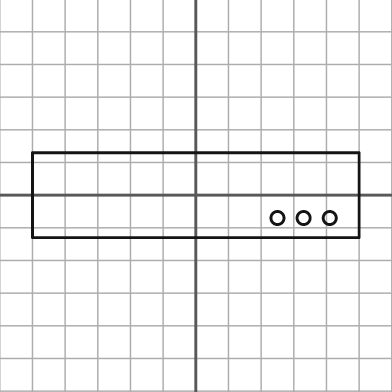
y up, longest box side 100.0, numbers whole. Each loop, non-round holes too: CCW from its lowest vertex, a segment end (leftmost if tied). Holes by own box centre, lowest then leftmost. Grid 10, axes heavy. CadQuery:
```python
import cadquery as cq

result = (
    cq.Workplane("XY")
    .moveTo(-50.0, -13.0)
    .lineTo(50.0, -13.0)
    .lineTo(50.0, 13.0)
    .lineTo(-50.0, 13.0)
    .close()
    .moveTo(25.0, -7.0)
    .circle(2.0)
    .moveTo(33.0, -7.0)
    .circle(2.0)
    .moveTo(41.0, -7.0)
    .circle(2.0)
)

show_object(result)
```